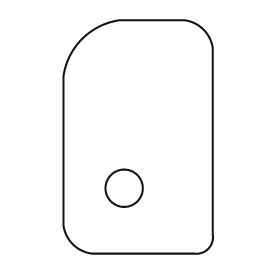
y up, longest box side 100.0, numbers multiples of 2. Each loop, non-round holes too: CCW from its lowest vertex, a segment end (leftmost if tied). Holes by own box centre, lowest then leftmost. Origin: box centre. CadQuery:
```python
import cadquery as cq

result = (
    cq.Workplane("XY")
    .moveTo(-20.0, -50.0)
    .lineTo(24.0, -50.0)
    .threePointArc((30.0, -48.0), (32.0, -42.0))
    .lineTo(32.0, 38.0)
    .threePointArc((28.0, 46.0), (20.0, 50.0))
    .lineTo(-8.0, 50.0)
    .threePointArc((-24.0, 42.0), (-32.0, 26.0))
    .lineTo(-32.0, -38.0)
    .threePointArc((-28.0, -46.0), (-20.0, -50.0))
    .close()
    .moveTo(-6.0, -22.0)
    .circle(8.0)
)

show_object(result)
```